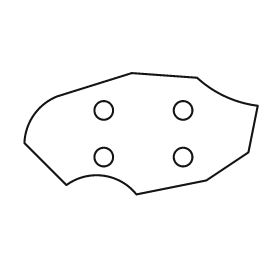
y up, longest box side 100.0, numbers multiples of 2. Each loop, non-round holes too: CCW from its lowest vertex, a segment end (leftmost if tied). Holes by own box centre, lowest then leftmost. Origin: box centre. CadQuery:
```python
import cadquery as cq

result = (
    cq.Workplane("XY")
    .moveTo(-2.0, -26.0)
    .lineTo(28.0, -20.0)
    .lineTo(46.0, -8.0)
    .lineTo(50.0, 12.0)
    .threePointArc((36.0, 16.0), (24.0, 24.0))
    .lineTo(-4.0, 26.0)
    .lineTo(-36.0, 16.0)
    .threePointArc((-46.0, 8.0), (-50.0, -4.0))
    .lineTo(-32.0, -22.0)
    .threePointArc((-16.0, -18.0), (-2.0, -26.0))
    .close()
    .moveTo(-16.0, -10.0)
    .circle(4.0)
    .moveTo(18.0, -10.0)
    .circle(4.0)
    .moveTo(-16.0, 10.0)
    .circle(4.0)
    .moveTo(18.0, 10.0)
    .circle(4.0)
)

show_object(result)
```